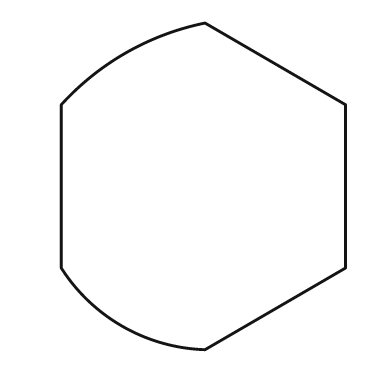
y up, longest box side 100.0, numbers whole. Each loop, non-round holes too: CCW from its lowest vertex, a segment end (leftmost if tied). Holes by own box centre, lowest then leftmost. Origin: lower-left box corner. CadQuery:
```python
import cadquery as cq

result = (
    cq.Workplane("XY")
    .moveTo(44.0, 0.0)
    .lineTo(87.0, 25.0)
    .lineTo(87.0, 75.0)
    .lineTo(44.0, 100.0)
    .threePointArc((20.0, 91.0), (0.0, 75.0))
    .lineTo(0.0, 25.0)
    .threePointArc((19.0, 7.0), (44.0, 0.0))
    .close()
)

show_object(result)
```